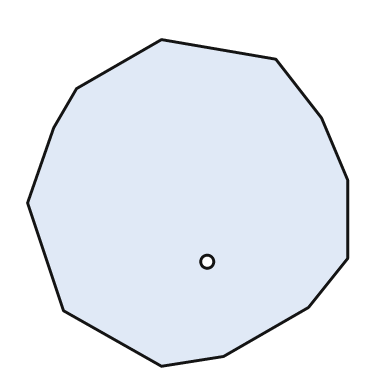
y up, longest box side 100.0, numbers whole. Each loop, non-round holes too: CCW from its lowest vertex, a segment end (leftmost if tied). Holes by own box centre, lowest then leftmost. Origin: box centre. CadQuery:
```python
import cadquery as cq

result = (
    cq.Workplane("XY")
    .moveTo(-8.0, -50.0)
    .lineTo(11.0, -47.0)
    .lineTo(37.0, -32.0)
    .lineTo(49.0, -17.0)
    .lineTo(49.0, 7.0)
    .lineTo(41.0, 26.0)
    .lineTo(27.0, 44.0)
    .lineTo(-8.0, 50.0)
    .lineTo(-34.0, 35.0)
    .lineTo(-41.0, 23.0)
    .lineTo(-49.0, 0.0)
    .lineTo(-38.0, -33.0)
    .close()
    .moveTo(6.0, -18.0)
    .circle(2.0)
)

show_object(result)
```